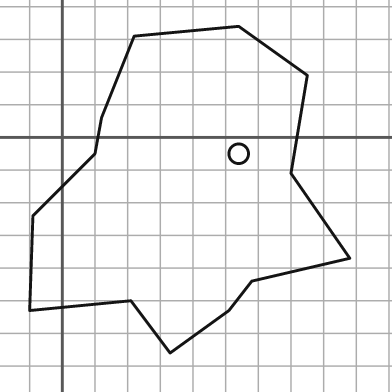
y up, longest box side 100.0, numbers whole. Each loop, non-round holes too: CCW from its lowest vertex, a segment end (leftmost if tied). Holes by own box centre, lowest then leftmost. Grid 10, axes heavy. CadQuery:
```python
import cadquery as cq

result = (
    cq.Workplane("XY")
    .moveTo(33.0, -66.0)
    .lineTo(51.0, -53.0)
    .lineTo(58.0, -44.0)
    .lineTo(88.0, -37.0)
    .lineTo(70.0, -11.0)
    .lineTo(75.0, 19.0)
    .lineTo(54.0, 34.0)
    .lineTo(22.0, 31.0)
    .lineTo(12.0, 6.0)
    .lineTo(10.0, -5.0)
    .lineTo(-9.0, -24.0)
    .lineTo(-10.0, -53.0)
    .lineTo(21.0, -50.0)
    .close()
    .moveTo(54.0, -5.0)
    .circle(3.0)
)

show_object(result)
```